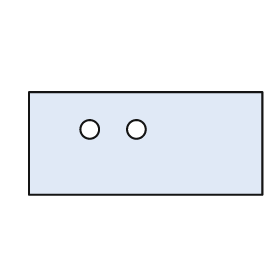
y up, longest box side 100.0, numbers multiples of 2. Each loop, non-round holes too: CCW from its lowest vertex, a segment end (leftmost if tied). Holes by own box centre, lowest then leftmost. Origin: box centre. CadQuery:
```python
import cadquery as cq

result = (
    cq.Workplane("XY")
    .moveTo(-50.0, -22.0)
    .lineTo(50.0, -22.0)
    .lineTo(50.0, 22.0)
    .lineTo(-50.0, 22.0)
    .close()
    .moveTo(-24.0, 6.0)
    .circle(4.0)
    .moveTo(-4.0, 6.0)
    .circle(4.0)
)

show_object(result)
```